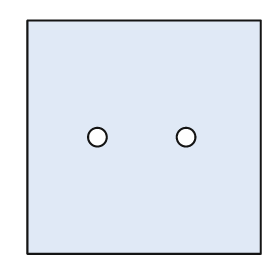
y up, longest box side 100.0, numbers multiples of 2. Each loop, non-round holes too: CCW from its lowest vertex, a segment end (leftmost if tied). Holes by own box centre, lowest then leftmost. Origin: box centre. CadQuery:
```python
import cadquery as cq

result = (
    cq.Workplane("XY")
    .moveTo(-50.0, -50.0)
    .lineTo(50.0, -50.0)
    .lineTo(50.0, 50.0)
    .lineTo(-50.0, 50.0)
    .close()
    .moveTo(-20.0, 0.0)
    .circle(4.0)
    .moveTo(18.0, 0.0)
    .circle(4.0)
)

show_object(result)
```